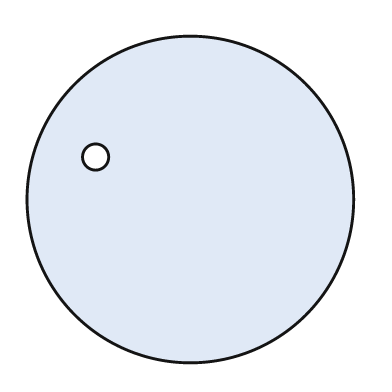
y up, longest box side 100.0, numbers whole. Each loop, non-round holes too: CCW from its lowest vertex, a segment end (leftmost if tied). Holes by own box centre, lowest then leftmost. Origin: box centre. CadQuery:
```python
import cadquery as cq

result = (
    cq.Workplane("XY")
    .moveTo(0.0, 0.0)
    .circle(50.0)
    .moveTo(-29.0, 13.0)
    .circle(4.0)
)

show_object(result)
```